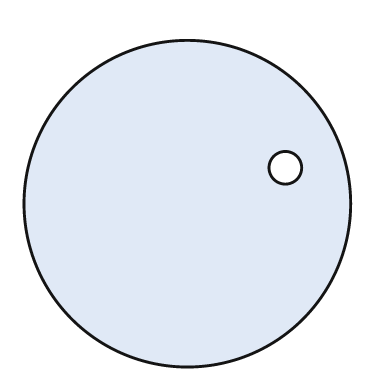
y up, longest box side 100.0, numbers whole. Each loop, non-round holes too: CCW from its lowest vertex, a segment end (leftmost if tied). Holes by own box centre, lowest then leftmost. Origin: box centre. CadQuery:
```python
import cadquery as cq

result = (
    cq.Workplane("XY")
    .moveTo(0.0, 0.0)
    .circle(50.0)
    .moveTo(30.0, 11.0)
    .circle(5.0)
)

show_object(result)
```